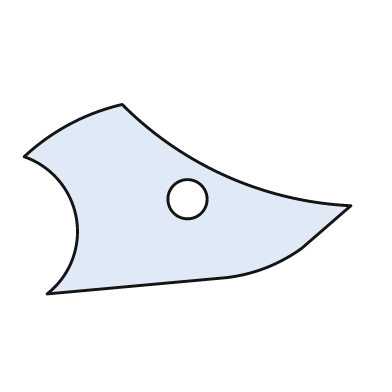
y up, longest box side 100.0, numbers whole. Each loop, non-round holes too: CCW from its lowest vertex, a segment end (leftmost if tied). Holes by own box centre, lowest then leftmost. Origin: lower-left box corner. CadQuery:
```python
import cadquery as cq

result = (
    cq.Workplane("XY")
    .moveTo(7.0, 0.0)
    .lineTo(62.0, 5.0)
    .threePointArc((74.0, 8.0), (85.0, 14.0))
    .lineTo(100.0, 27.0)
    .threePointArc((62.0, 36.0), (30.0, 58.0))
    .threePointArc((14.0, 52.0), (0.0, 42.0))
    .threePointArc((16.0, 23.0), (7.0, 0.0))
    .close()
    .moveTo(50.0, 29.0)
    .circle(6.0)
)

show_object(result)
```